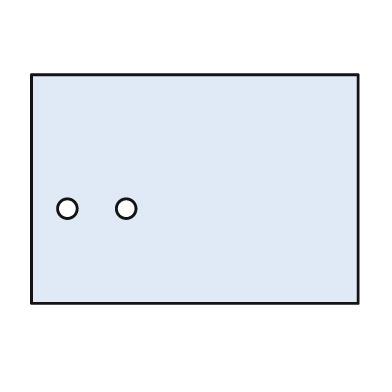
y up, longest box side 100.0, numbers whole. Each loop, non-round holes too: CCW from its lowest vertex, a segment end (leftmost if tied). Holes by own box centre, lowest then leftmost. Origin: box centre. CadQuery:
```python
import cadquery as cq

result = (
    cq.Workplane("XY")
    .moveTo(-50.0, -35.0)
    .lineTo(50.0, -35.0)
    .lineTo(50.0, 35.0)
    .lineTo(-50.0, 35.0)
    .close()
    .moveTo(-39.0, -6.0)
    .circle(3.0)
    .moveTo(-21.0, -6.0)
    .circle(3.0)
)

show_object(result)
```